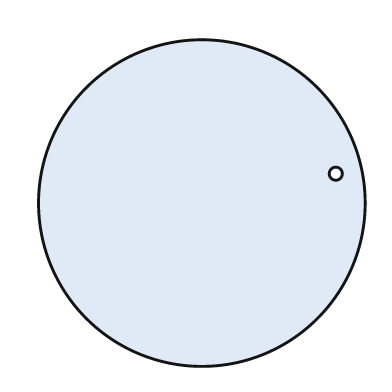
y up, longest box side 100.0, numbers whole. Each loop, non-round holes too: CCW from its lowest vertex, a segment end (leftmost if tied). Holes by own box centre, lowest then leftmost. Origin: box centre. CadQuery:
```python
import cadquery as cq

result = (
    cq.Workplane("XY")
    .moveTo(0.0, 0.0)
    .circle(50.0)
    .moveTo(41.0, 9.0)
    .circle(2.0)
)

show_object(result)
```